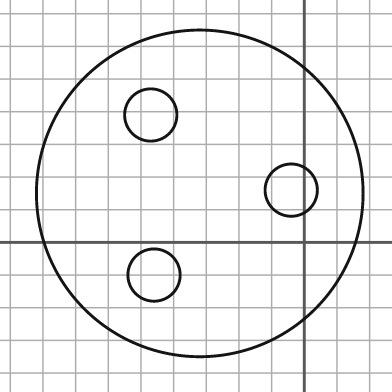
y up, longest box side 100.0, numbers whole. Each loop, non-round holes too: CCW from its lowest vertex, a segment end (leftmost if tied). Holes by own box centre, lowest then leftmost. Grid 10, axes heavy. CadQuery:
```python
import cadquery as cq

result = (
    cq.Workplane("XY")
    .moveTo(-32.0, 15.0)
    .circle(50.0)
    .moveTo(-46.0, -10.0)
    .circle(8.0)
    .moveTo(-4.0, 16.0)
    .circle(8.0)
    .moveTo(-47.0, 39.0)
    .circle(8.0)
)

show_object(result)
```